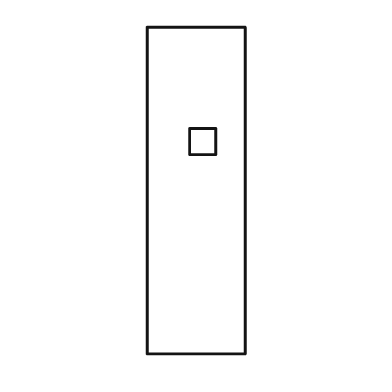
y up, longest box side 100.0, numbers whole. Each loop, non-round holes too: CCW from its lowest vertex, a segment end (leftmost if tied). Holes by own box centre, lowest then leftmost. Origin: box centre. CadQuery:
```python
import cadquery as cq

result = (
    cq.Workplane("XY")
    .moveTo(-15.0, -50.0)
    .lineTo(15.0, -50.0)
    .lineTo(15.0, 50.0)
    .lineTo(-15.0, 50.0)
    .close()
    .moveTo(-2.0, 11.0)
    .lineTo(6.0, 11.0)
    .lineTo(6.0, 19.0)
    .lineTo(-2.0, 19.0)
    .close()
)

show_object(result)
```